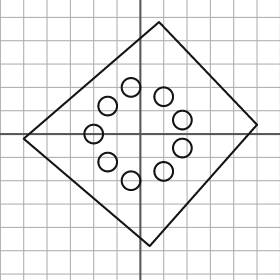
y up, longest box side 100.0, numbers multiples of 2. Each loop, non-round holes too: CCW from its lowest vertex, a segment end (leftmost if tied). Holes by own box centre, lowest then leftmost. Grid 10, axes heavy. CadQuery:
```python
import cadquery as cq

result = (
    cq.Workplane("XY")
    .moveTo(4.0, -48.0)
    .lineTo(50.0, 4.0)
    .lineTo(8.0, 48.0)
    .lineTo(-50.0, -2.0)
    .close()
    .moveTo(-4.0, -20.0)
    .circle(4.0)
    .moveTo(10.0, -16.0)
    .circle(4.0)
    .moveTo(-14.0, -12.0)
    .circle(4.0)
    .moveTo(18.0, -6.0)
    .circle(4.0)
    .moveTo(-20.0, 0.0)
    .circle(4.0)
    .moveTo(18.0, 6.0)
    .circle(4.0)
    .moveTo(-14.0, 12.0)
    .circle(4.0)
    .moveTo(10.0, 16.0)
    .circle(4.0)
    .moveTo(-4.0, 20.0)
    .circle(4.0)
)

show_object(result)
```